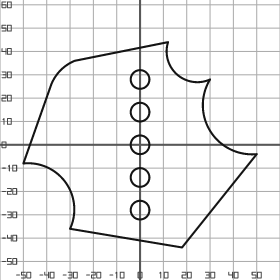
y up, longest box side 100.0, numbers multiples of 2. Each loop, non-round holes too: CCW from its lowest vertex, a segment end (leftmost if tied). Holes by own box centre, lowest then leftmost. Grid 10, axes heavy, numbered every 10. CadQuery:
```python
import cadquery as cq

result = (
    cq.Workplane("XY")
    .moveTo(18.0, -44.0)
    .lineTo(50.0, -4.0)
    .threePointArc((30.0, 6.0), (30.0, 28.0))
    .threePointArc((16.0, 30.0), (12.0, 44.0))
    .lineTo(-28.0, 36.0)
    .threePointArc((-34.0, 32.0), (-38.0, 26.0))
    .lineTo(-50.0, -8.0)
    .threePointArc((-32.0, -16.0), (-30.0, -36.0))
    .close()
    .moveTo(0.0, -28.0)
    .circle(4.0)
    .moveTo(0.0, -14.0)
    .circle(4.0)
    .moveTo(0.0, 0.0)
    .circle(4.0)
    .moveTo(0.0, 14.0)
    .circle(4.0)
    .moveTo(0.0, 28.0)
    .circle(4.0)
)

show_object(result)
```